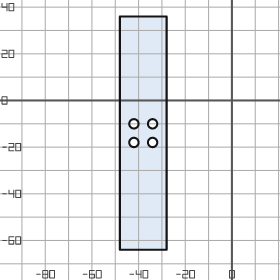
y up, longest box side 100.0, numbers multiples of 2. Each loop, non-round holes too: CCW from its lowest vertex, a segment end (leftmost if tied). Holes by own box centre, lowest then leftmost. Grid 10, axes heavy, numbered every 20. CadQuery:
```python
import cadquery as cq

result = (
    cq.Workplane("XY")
    .moveTo(-48.0, -64.0)
    .lineTo(-28.0, -64.0)
    .lineTo(-28.0, 36.0)
    .lineTo(-48.0, 36.0)
    .close()
    .moveTo(-42.0, -18.0)
    .circle(2.0)
    .moveTo(-34.0, -18.0)
    .circle(2.0)
    .moveTo(-42.0, -10.0)
    .circle(2.0)
    .moveTo(-34.0, -10.0)
    .circle(2.0)
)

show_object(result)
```